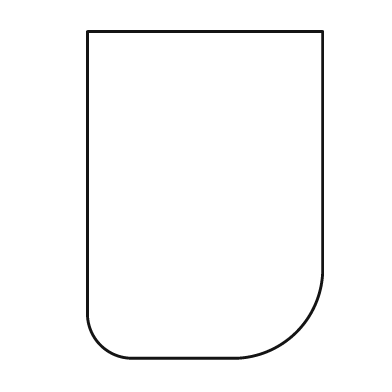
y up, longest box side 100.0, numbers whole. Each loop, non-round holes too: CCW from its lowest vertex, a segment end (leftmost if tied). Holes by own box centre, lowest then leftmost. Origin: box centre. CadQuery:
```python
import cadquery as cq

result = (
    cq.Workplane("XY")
    .moveTo(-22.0, -50.0)
    .lineTo(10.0, -50.0)
    .threePointArc((28.0, -42.0), (36.0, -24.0))
    .lineTo(36.0, 50.0)
    .lineTo(-36.0, 50.0)
    .lineTo(-36.0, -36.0)
    .threePointArc((-32.0, -46.0), (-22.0, -50.0))
    .close()
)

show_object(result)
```